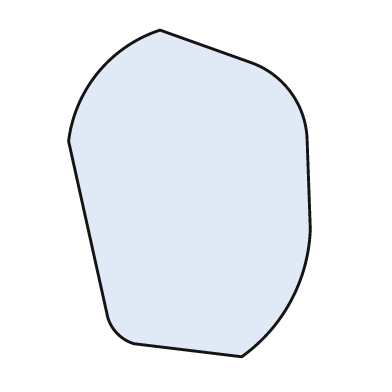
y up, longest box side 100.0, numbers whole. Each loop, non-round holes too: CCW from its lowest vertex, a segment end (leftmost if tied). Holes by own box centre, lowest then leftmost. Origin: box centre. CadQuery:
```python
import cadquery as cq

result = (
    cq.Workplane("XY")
    .moveTo(16.0, -50.0)
    .threePointArc((31.0, -33.0), (37.0, -11.0))
    .lineTo(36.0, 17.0)
    .threePointArc((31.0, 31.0), (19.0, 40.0))
    .lineTo(-9.0, 50.0)
    .threePointArc((-28.0, 37.0), (-37.0, 16.0))
    .lineTo(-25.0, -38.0)
    .threePointArc((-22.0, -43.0), (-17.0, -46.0))
    .close()
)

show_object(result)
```